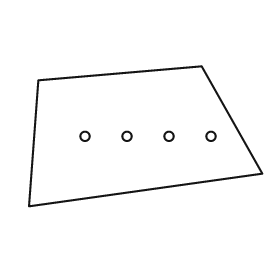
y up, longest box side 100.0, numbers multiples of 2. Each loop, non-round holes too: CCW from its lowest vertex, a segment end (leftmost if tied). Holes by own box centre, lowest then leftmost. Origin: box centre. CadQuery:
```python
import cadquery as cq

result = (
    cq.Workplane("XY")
    .moveTo(-50.0, -30.0)
    .lineTo(50.0, -16.0)
    .lineTo(24.0, 30.0)
    .lineTo(-46.0, 24.0)
    .close()
    .moveTo(-26.0, 0.0)
    .circle(2.0)
    .moveTo(-8.0, 0.0)
    .circle(2.0)
    .moveTo(10.0, 0.0)
    .circle(2.0)
    .moveTo(28.0, 0.0)
    .circle(2.0)
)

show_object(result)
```